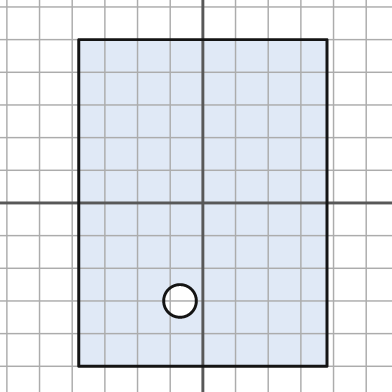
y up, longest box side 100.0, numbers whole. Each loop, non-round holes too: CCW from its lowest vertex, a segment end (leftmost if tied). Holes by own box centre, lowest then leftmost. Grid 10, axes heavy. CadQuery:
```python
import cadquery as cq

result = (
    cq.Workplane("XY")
    .moveTo(-38.0, -50.0)
    .lineTo(38.0, -50.0)
    .lineTo(38.0, 50.0)
    .lineTo(-38.0, 50.0)
    .close()
    .moveTo(-7.0, -30.0)
    .circle(5.0)
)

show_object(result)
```